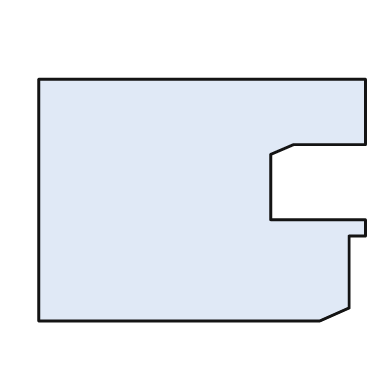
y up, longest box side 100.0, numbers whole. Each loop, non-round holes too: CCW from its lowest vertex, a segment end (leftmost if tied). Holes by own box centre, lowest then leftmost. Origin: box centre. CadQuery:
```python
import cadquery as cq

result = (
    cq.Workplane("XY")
    .moveTo(-50.0, -37.0)
    .lineTo(36.0, -37.0)
    .lineTo(45.0, -33.0)
    .lineTo(45.0, -11.0)
    .lineTo(50.0, -11.0)
    .lineTo(50.0, -6.0)
    .lineTo(21.0, -6.0)
    .lineTo(21.0, 14.0)
    .lineTo(28.0, 17.0)
    .lineTo(50.0, 17.0)
    .lineTo(50.0, 37.0)
    .lineTo(-50.0, 37.0)
    .close()
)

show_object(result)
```